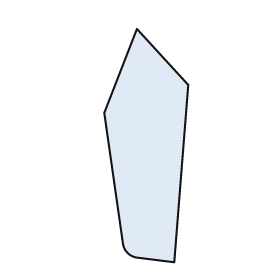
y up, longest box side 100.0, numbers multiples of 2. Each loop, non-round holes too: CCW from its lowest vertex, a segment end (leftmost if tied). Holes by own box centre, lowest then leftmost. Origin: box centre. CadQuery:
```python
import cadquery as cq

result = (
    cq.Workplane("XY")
    .moveTo(12.0, -50.0)
    .lineTo(18.0, 26.0)
    .lineTo(-4.0, 50.0)
    .lineTo(-18.0, 14.0)
    .lineTo(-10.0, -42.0)
    .threePointArc((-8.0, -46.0), (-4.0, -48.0))
    .close()
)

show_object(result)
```